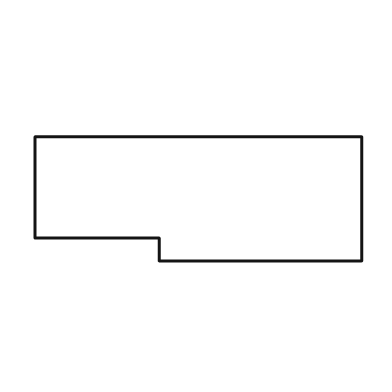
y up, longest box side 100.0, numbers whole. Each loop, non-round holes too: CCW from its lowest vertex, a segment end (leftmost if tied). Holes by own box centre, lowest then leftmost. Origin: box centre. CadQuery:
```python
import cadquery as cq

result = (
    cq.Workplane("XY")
    .moveTo(-12.0, -19.0)
    .lineTo(50.0, -19.0)
    .lineTo(50.0, 19.0)
    .lineTo(-50.0, 19.0)
    .lineTo(-50.0, -12.0)
    .lineTo(-12.0, -12.0)
    .close()
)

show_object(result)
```